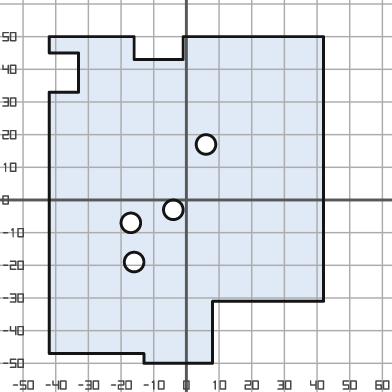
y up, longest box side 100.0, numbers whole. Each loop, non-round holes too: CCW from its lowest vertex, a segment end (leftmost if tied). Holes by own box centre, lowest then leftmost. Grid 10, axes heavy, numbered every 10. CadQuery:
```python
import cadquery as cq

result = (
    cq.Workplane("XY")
    .moveTo(-13.0, -50.0)
    .lineTo(8.0, -50.0)
    .lineTo(8.0, -31.0)
    .lineTo(42.0, -31.0)
    .lineTo(42.0, 50.0)
    .lineTo(-1.0, 50.0)
    .lineTo(-1.0, 43.0)
    .lineTo(-16.0, 43.0)
    .lineTo(-16.0, 50.0)
    .lineTo(-42.0, 50.0)
    .lineTo(-42.0, 45.0)
    .lineTo(-33.0, 45.0)
    .lineTo(-33.0, 33.0)
    .lineTo(-42.0, 33.0)
    .lineTo(-42.0, -47.0)
    .lineTo(-13.0, -47.0)
    .close()
    .moveTo(-16.0, -19.0)
    .circle(3.0)
    .moveTo(-17.0, -7.0)
    .circle(3.0)
    .moveTo(-4.0, -3.0)
    .circle(3.0)
    .moveTo(6.0, 17.0)
    .circle(3.0)
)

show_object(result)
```